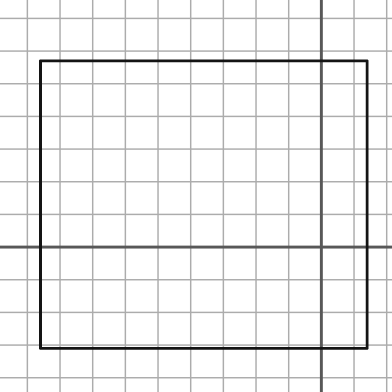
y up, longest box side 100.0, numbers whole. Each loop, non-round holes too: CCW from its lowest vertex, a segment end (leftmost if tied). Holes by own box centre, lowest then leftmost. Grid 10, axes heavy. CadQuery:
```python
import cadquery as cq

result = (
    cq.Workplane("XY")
    .moveTo(-86.0, -31.0)
    .lineTo(14.0, -31.0)
    .lineTo(14.0, 57.0)
    .lineTo(-86.0, 57.0)
    .close()
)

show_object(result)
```